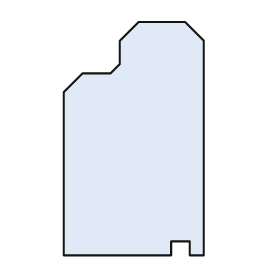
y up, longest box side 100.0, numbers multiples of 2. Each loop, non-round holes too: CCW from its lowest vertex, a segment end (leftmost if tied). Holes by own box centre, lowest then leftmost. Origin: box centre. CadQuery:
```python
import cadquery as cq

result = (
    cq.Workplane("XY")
    .moveTo(-30.0, -50.0)
    .lineTo(16.0, -50.0)
    .lineTo(16.0, -44.0)
    .lineTo(24.0, -44.0)
    .lineTo(24.0, -50.0)
    .lineTo(30.0, -50.0)
    .lineTo(30.0, 42.0)
    .lineTo(22.0, 50.0)
    .lineTo(2.0, 50.0)
    .lineTo(-6.0, 42.0)
    .lineTo(-6.0, 32.0)
    .lineTo(-10.0, 28.0)
    .lineTo(-22.0, 28.0)
    .lineTo(-30.0, 20.0)
    .close()
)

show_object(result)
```